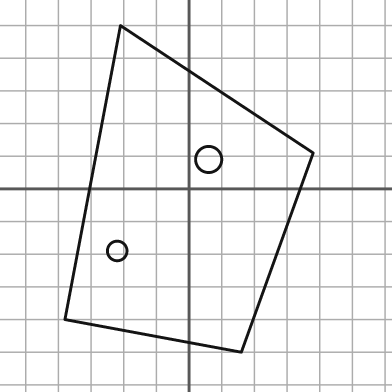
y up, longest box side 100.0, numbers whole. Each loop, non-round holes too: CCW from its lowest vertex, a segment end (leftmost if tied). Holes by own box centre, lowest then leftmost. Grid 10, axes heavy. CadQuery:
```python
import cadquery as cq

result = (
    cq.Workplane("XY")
    .moveTo(16.0, -50.0)
    .lineTo(38.0, 11.0)
    .lineTo(-21.0, 50.0)
    .lineTo(-38.0, -40.0)
    .close()
    .moveTo(-22.0, -19.0)
    .circle(3.0)
    .moveTo(6.0, 9.0)
    .circle(4.0)
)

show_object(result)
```